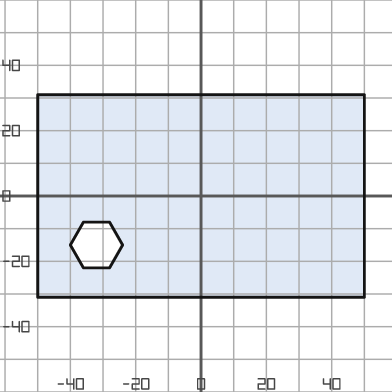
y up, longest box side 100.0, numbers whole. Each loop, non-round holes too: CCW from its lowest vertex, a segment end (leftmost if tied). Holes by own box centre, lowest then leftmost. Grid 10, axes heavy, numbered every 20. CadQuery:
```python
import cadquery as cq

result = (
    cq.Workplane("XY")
    .moveTo(-50.0, -31.0)
    .lineTo(50.0, -31.0)
    .lineTo(50.0, 31.0)
    .lineTo(-50.0, 31.0)
    .close()
    .moveTo(-36.0, -22.0)
    .lineTo(-28.0, -22.0)
    .lineTo(-24.0, -15.0)
    .lineTo(-28.0, -8.0)
    .lineTo(-36.0, -8.0)
    .lineTo(-40.0, -15.0)
    .close()
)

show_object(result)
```